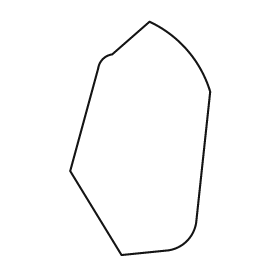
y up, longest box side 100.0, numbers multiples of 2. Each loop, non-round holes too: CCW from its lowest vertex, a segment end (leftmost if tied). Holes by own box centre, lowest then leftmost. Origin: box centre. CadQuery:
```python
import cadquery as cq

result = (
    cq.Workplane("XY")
    .moveTo(-8.0, -50.0)
    .lineTo(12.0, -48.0)
    .threePointArc((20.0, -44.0), (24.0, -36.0))
    .lineTo(30.0, 20.0)
    .threePointArc((20.0, 38.0), (4.0, 50.0))
    .lineTo(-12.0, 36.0)
    .threePointArc((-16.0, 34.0), (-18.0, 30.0))
    .lineTo(-30.0, -14.0)
    .close()
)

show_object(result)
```